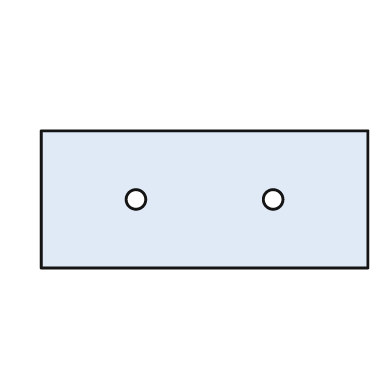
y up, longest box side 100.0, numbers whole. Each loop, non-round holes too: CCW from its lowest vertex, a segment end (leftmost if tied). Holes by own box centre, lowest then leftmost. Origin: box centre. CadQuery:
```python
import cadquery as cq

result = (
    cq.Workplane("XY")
    .moveTo(-50.0, -21.0)
    .lineTo(50.0, -21.0)
    .lineTo(50.0, 21.0)
    .lineTo(-50.0, 21.0)
    .close()
    .moveTo(-21.0, 0.0)
    .circle(3.0)
    .moveTo(21.0, 0.0)
    .circle(3.0)
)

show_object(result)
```